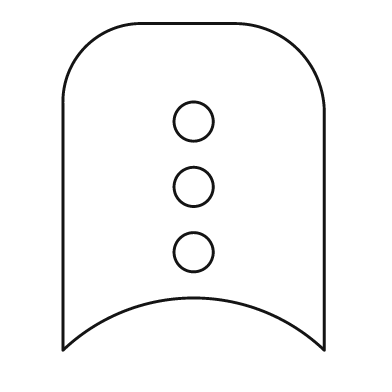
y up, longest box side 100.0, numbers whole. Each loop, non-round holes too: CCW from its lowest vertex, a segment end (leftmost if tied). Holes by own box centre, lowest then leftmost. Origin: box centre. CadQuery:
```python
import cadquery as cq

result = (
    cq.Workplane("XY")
    .moveTo(-40.0, -50.0)
    .threePointArc((0.0, -34.0), (40.0, -50.0))
    .lineTo(40.0, 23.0)
    .threePointArc((32.0, 42.0), (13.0, 50.0))
    .lineTo(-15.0, 50.0)
    .threePointArc((-33.0, 43.0), (-40.0, 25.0))
    .close()
    .moveTo(0.0, -20.0)
    .circle(6.0)
    .moveTo(0.0, 0.0)
    .circle(6.0)
    .moveTo(0.0, 20.0)
    .circle(6.0)
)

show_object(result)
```